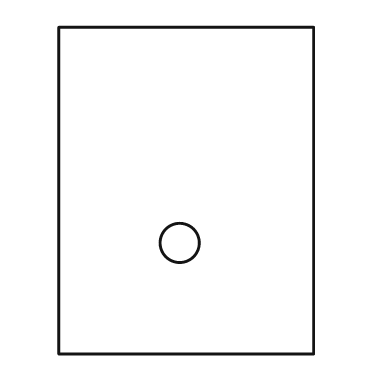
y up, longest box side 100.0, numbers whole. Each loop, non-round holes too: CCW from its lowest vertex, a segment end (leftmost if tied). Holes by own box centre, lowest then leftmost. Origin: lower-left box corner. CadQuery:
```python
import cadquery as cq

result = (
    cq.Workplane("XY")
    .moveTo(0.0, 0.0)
    .lineTo(78.0, 0.0)
    .lineTo(78.0, 100.0)
    .lineTo(0.0, 100.0)
    .close()
    .moveTo(37.0, 34.0)
    .circle(6.0)
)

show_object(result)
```